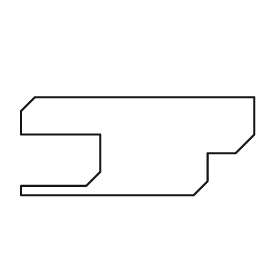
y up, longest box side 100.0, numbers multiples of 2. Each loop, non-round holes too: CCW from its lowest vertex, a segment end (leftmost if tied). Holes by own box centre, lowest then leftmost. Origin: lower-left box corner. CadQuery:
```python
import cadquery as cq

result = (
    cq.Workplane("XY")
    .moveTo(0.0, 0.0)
    .lineTo(74.0, 0.0)
    .lineTo(80.0, 6.0)
    .lineTo(80.0, 18.0)
    .lineTo(92.0, 18.0)
    .lineTo(100.0, 26.0)
    .lineTo(100.0, 42.0)
    .lineTo(6.0, 42.0)
    .lineTo(0.0, 36.0)
    .lineTo(0.0, 26.0)
    .lineTo(34.0, 26.0)
    .lineTo(34.0, 10.0)
    .lineTo(28.0, 4.0)
    .lineTo(0.0, 4.0)
    .close()
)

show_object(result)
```